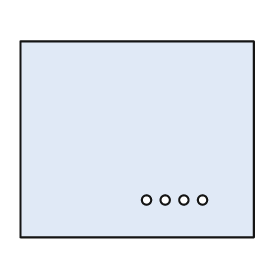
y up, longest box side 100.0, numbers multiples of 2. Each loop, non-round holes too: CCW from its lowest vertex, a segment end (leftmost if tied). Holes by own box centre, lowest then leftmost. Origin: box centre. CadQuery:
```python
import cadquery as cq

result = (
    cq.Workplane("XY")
    .moveTo(-50.0, -42.0)
    .lineTo(50.0, -42.0)
    .lineTo(50.0, 42.0)
    .lineTo(-50.0, 42.0)
    .close()
    .moveTo(4.0, -26.0)
    .circle(2.0)
    .moveTo(12.0, -26.0)
    .circle(2.0)
    .moveTo(20.0, -26.0)
    .circle(2.0)
    .moveTo(28.0, -26.0)
    .circle(2.0)
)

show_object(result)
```